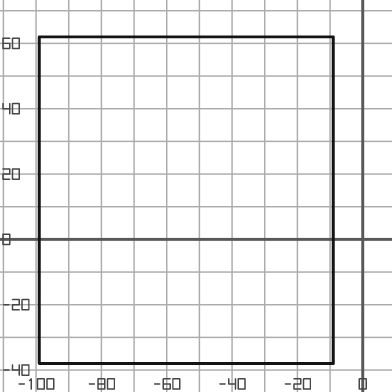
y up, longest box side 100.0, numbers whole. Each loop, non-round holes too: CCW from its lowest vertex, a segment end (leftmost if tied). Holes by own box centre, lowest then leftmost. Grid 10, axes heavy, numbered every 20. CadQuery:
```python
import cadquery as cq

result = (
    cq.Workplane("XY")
    .moveTo(-99.0, -38.0)
    .lineTo(-9.0, -38.0)
    .lineTo(-9.0, 62.0)
    .lineTo(-99.0, 62.0)
    .close()
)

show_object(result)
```